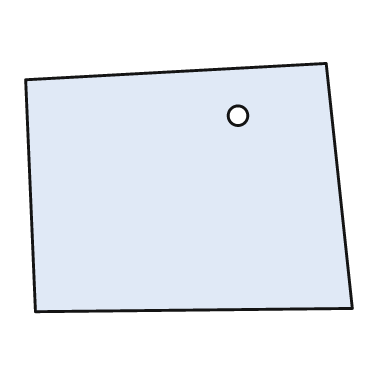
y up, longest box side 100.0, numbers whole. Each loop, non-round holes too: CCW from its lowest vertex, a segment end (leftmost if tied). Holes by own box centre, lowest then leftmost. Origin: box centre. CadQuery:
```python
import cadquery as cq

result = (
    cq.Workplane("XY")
    .moveTo(-47.0, -38.0)
    .lineTo(50.0, -37.0)
    .lineTo(42.0, 38.0)
    .lineTo(-50.0, 33.0)
    .close()
    .moveTo(15.0, 22.0)
    .circle(3.0)
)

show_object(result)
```